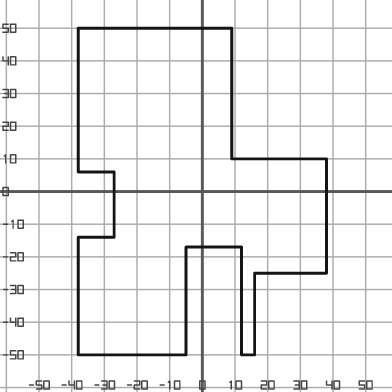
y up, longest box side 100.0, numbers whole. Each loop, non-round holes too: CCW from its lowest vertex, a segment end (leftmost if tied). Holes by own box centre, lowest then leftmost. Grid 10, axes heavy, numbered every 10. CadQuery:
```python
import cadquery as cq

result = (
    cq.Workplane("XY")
    .moveTo(-38.0, -50.0)
    .lineTo(-5.0, -50.0)
    .lineTo(-5.0, -17.0)
    .lineTo(12.0, -17.0)
    .lineTo(12.0, -50.0)
    .lineTo(16.0, -50.0)
    .lineTo(16.0, -25.0)
    .lineTo(38.0, -25.0)
    .lineTo(38.0, 10.0)
    .lineTo(9.0, 10.0)
    .lineTo(9.0, 50.0)
    .lineTo(-38.0, 50.0)
    .lineTo(-38.0, 6.0)
    .lineTo(-27.0, 6.0)
    .lineTo(-27.0, -14.0)
    .lineTo(-38.0, -14.0)
    .close()
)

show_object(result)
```